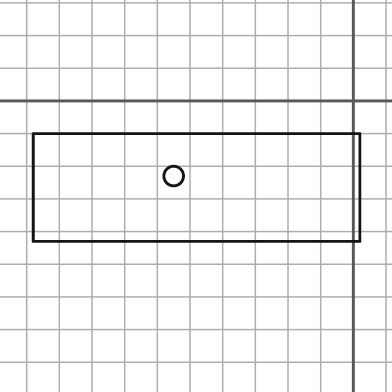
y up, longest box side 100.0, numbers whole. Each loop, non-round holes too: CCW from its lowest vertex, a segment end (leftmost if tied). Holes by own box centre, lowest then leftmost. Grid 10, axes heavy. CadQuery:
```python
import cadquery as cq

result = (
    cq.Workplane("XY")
    .moveTo(-98.0, -43.0)
    .lineTo(2.0, -43.0)
    .lineTo(2.0, -10.0)
    .lineTo(-98.0, -10.0)
    .close()
    .moveTo(-55.0, -23.0)
    .circle(3.0)
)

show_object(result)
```